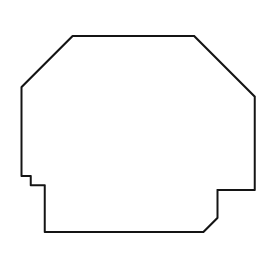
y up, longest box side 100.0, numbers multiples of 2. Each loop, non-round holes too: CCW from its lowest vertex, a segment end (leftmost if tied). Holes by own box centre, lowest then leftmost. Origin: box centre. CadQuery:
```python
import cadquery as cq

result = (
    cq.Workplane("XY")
    .moveTo(-40.0, -42.0)
    .lineTo(28.0, -42.0)
    .lineTo(34.0, -36.0)
    .lineTo(34.0, -24.0)
    .lineTo(50.0, -24.0)
    .lineTo(50.0, 16.0)
    .lineTo(24.0, 42.0)
    .lineTo(-28.0, 42.0)
    .lineTo(-50.0, 20.0)
    .lineTo(-50.0, -18.0)
    .lineTo(-46.0, -18.0)
    .lineTo(-46.0, -22.0)
    .lineTo(-40.0, -22.0)
    .close()
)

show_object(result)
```